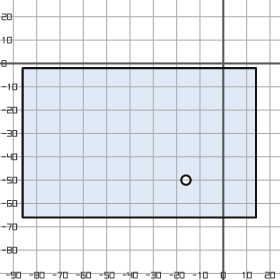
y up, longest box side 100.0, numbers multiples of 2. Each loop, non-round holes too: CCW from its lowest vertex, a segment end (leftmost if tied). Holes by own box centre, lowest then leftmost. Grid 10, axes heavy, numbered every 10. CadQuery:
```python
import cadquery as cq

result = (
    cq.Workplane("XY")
    .moveTo(-86.0, -66.0)
    .lineTo(14.0, -66.0)
    .lineTo(14.0, -2.0)
    .lineTo(-86.0, -2.0)
    .close()
    .moveTo(-16.0, -50.0)
    .circle(2.0)
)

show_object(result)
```